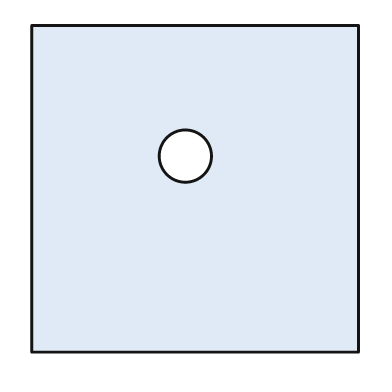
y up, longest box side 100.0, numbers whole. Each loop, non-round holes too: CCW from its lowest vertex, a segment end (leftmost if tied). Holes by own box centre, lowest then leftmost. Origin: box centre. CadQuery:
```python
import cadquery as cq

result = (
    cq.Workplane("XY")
    .moveTo(-50.0, -50.0)
    .lineTo(50.0, -50.0)
    .lineTo(50.0, 50.0)
    .lineTo(-50.0, 50.0)
    .close()
    .moveTo(-3.0, 10.0)
    .circle(8.0)
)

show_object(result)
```